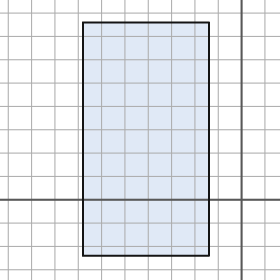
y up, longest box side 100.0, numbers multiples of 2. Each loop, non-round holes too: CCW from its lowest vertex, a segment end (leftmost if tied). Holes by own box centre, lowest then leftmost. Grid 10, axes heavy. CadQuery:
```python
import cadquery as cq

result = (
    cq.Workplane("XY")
    .moveTo(-68.0, -24.0)
    .lineTo(-14.0, -24.0)
    .lineTo(-14.0, 76.0)
    .lineTo(-68.0, 76.0)
    .close()
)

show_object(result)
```